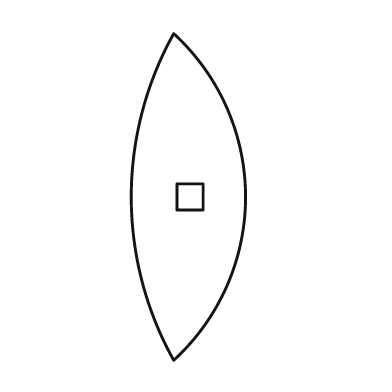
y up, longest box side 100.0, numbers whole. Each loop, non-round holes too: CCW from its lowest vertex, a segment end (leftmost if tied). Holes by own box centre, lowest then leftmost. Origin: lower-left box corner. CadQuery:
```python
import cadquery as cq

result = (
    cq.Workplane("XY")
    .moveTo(13.0, 0.0)
    .threePointArc((35.0, 50.0), (13.0, 100.0))
    .threePointArc((0.0, 50.0), (13.0, 0.0))
    .close()
    .moveTo(14.0, 46.0)
    .lineTo(22.0, 46.0)
    .lineTo(22.0, 54.0)
    .lineTo(14.0, 54.0)
    .close()
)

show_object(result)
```